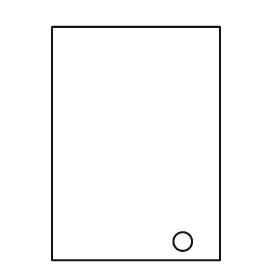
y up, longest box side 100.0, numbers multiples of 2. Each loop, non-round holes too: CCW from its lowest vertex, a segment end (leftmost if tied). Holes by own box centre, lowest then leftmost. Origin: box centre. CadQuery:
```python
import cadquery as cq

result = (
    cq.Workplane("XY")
    .moveTo(-36.0, -50.0)
    .lineTo(36.0, -50.0)
    .lineTo(36.0, 50.0)
    .lineTo(-36.0, 50.0)
    .close()
    .moveTo(20.0, -42.0)
    .circle(4.0)
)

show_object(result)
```